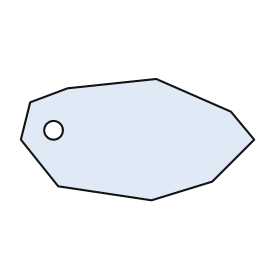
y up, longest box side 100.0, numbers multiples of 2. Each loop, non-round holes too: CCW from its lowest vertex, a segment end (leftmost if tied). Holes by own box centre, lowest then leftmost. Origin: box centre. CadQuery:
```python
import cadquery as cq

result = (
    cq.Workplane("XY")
    .moveTo(6.0, -26.0)
    .lineTo(32.0, -18.0)
    .lineTo(50.0, 0.0)
    .lineTo(40.0, 12.0)
    .lineTo(8.0, 26.0)
    .lineTo(-30.0, 22.0)
    .lineTo(-46.0, 16.0)
    .lineTo(-50.0, 0.0)
    .lineTo(-34.0, -20.0)
    .close()
    .moveTo(-36.0, 4.0)
    .circle(4.0)
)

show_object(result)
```